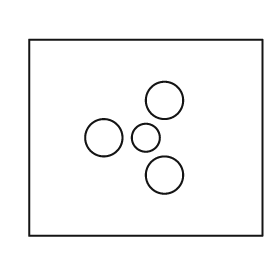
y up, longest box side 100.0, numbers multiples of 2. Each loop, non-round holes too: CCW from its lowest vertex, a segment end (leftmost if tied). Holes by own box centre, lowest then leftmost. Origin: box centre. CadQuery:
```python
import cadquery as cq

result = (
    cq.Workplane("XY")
    .moveTo(-50.0, -42.0)
    .lineTo(50.0, -42.0)
    .lineTo(50.0, 42.0)
    .lineTo(-50.0, 42.0)
    .close()
    .moveTo(8.0, -16.0)
    .circle(8.0)
    .moveTo(-18.0, 0.0)
    .circle(8.0)
    .moveTo(0.0, 0.0)
    .circle(6.0)
    .moveTo(8.0, 16.0)
    .circle(8.0)
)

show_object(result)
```